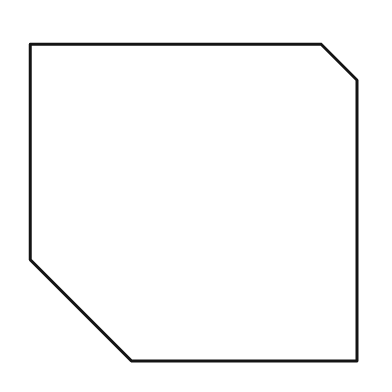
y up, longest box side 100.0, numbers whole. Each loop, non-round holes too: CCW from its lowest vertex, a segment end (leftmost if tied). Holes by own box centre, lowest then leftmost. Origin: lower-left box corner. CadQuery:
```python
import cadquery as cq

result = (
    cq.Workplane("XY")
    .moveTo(31.0, 0.0)
    .lineTo(100.0, 0.0)
    .lineTo(100.0, 86.0)
    .lineTo(89.0, 97.0)
    .lineTo(0.0, 97.0)
    .lineTo(0.0, 31.0)
    .close()
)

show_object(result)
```